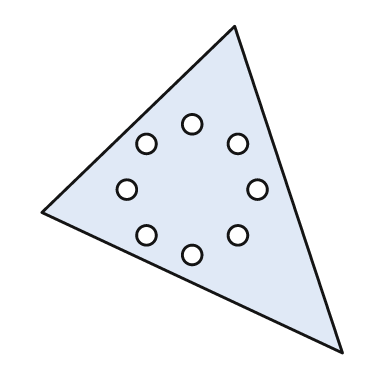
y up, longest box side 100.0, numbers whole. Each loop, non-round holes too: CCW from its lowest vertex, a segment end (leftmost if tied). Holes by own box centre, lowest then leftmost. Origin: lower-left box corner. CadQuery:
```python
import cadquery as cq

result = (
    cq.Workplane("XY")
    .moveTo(92.0, 0.0)
    .lineTo(59.0, 100.0)
    .lineTo(0.0, 43.0)
    .close()
    .moveTo(46.0, 30.0)
    .circle(3.0)
    .moveTo(32.0, 36.0)
    .circle(3.0)
    .moveTo(60.0, 36.0)
    .circle(3.0)
    .moveTo(26.0, 50.0)
    .circle(3.0)
    .moveTo(66.0, 50.0)
    .circle(3.0)
    .moveTo(32.0, 64.0)
    .circle(3.0)
    .moveTo(60.0, 64.0)
    .circle(3.0)
    .moveTo(46.0, 70.0)
    .circle(3.0)
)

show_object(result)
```